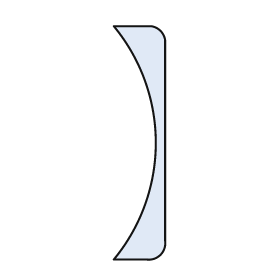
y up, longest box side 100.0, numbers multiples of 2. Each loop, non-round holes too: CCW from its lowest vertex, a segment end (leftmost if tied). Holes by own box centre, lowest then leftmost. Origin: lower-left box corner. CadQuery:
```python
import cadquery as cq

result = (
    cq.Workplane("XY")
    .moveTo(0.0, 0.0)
    .lineTo(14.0, 0.0)
    .threePointArc((20.0, 2.0), (22.0, 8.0))
    .lineTo(22.0, 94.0)
    .threePointArc((20.0, 98.0), (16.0, 100.0))
    .lineTo(0.0, 100.0)
    .threePointArc((18.0, 50.0), (0.0, 0.0))
    .close()
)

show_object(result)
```